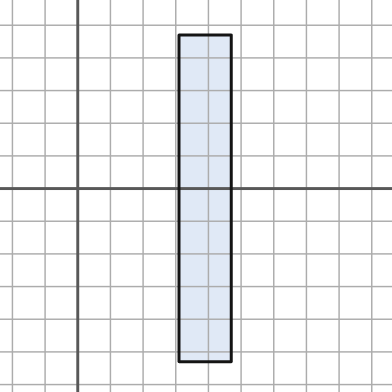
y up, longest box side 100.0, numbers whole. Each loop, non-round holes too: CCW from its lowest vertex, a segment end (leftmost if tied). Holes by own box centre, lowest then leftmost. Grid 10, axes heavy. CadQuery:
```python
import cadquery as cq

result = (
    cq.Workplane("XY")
    .moveTo(31.0, -53.0)
    .lineTo(47.0, -53.0)
    .lineTo(47.0, 47.0)
    .lineTo(31.0, 47.0)
    .close()
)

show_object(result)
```